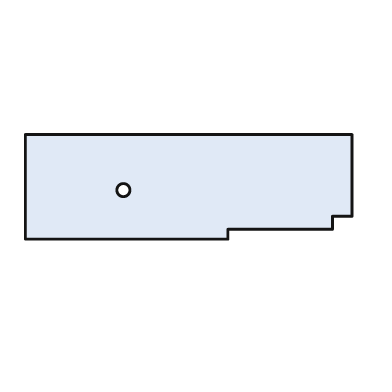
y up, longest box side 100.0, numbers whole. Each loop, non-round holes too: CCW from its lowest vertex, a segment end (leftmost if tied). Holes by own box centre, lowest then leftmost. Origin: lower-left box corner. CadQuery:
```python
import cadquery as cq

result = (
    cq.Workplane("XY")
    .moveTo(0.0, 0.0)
    .lineTo(62.0, 0.0)
    .lineTo(62.0, 3.0)
    .lineTo(94.0, 3.0)
    .lineTo(94.0, 7.0)
    .lineTo(100.0, 7.0)
    .lineTo(100.0, 32.0)
    .lineTo(0.0, 32.0)
    .close()
    .moveTo(30.0, 15.0)
    .circle(2.0)
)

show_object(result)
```